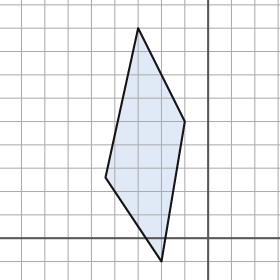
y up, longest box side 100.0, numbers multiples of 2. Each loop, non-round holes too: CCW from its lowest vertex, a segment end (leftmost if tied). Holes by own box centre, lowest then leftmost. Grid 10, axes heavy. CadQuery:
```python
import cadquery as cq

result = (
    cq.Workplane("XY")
    .moveTo(-20.0, -10.0)
    .lineTo(-10.0, 50.0)
    .lineTo(-30.0, 90.0)
    .lineTo(-44.0, 26.0)
    .close()
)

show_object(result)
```